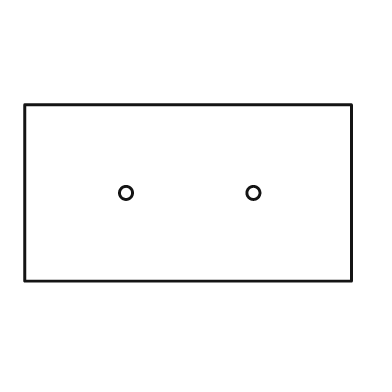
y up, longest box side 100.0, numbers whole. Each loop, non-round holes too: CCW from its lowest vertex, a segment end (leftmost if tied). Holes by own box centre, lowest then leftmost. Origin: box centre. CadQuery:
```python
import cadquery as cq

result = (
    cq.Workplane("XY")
    .moveTo(-50.0, -27.0)
    .lineTo(50.0, -27.0)
    .lineTo(50.0, 27.0)
    .lineTo(-50.0, 27.0)
    .close()
    .moveTo(-19.0, 0.0)
    .circle(2.0)
    .moveTo(20.0, 0.0)
    .circle(2.0)
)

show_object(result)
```